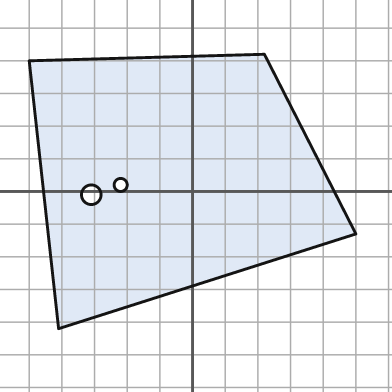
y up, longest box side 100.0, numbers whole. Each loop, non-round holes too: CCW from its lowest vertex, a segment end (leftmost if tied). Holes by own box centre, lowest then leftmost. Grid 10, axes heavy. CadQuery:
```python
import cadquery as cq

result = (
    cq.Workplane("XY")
    .moveTo(-41.0, -42.0)
    .lineTo(50.0, -13.0)
    .lineTo(22.0, 42.0)
    .lineTo(-50.0, 40.0)
    .close()
    .moveTo(-31.0, -1.0)
    .circle(3.0)
    .moveTo(-22.0, 2.0)
    .circle(2.0)
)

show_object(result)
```